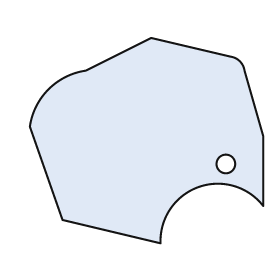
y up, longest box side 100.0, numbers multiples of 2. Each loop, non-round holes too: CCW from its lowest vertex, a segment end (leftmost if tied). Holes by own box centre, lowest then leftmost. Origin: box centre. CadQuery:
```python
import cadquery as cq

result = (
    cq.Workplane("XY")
    .moveTo(6.0, -44.0)
    .threePointArc((22.0, -20.0), (50.0, -28.0))
    .lineTo(50.0, 2.0)
    .lineTo(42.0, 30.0)
    .threePointArc((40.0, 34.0), (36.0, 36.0))
    .lineTo(2.0, 44.0)
    .lineTo(-26.0, 30.0)
    .threePointArc((-42.0, 22.0), (-50.0, 6.0))
    .lineTo(-36.0, -34.0)
    .close()
    .moveTo(34.0, -10.0)
    .circle(4.0)
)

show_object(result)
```